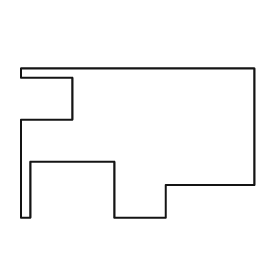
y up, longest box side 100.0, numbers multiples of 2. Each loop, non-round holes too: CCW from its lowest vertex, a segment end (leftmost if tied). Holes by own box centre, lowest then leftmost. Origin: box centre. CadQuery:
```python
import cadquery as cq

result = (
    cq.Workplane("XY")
    .moveTo(-50.0, -32.0)
    .lineTo(-46.0, -32.0)
    .lineTo(-46.0, -8.0)
    .lineTo(-10.0, -8.0)
    .lineTo(-10.0, -32.0)
    .lineTo(12.0, -32.0)
    .lineTo(12.0, -18.0)
    .lineTo(50.0, -18.0)
    .lineTo(50.0, 32.0)
    .lineTo(-50.0, 32.0)
    .lineTo(-50.0, 28.0)
    .lineTo(-28.0, 28.0)
    .lineTo(-28.0, 10.0)
    .lineTo(-50.0, 10.0)
    .close()
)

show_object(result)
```